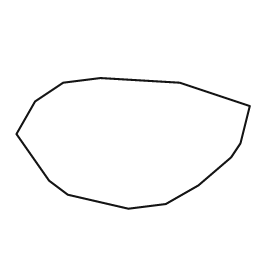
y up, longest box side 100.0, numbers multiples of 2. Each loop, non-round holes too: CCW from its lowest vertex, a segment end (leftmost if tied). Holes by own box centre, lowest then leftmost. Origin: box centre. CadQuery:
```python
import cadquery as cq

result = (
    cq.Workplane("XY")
    .moveTo(-2.0, -28.0)
    .lineTo(14.0, -26.0)
    .lineTo(28.0, -18.0)
    .lineTo(42.0, -6.0)
    .lineTo(46.0, 0.0)
    .lineTo(50.0, 16.0)
    .lineTo(20.0, 26.0)
    .lineTo(-14.0, 28.0)
    .lineTo(-30.0, 26.0)
    .lineTo(-42.0, 18.0)
    .lineTo(-50.0, 4.0)
    .lineTo(-36.0, -16.0)
    .lineTo(-28.0, -22.0)
    .close()
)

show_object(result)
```